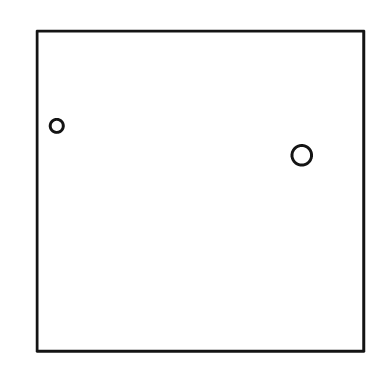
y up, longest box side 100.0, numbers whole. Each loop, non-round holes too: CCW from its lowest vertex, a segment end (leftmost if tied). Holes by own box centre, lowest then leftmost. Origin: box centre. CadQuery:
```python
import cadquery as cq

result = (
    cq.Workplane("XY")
    .moveTo(-50.0, -49.0)
    .lineTo(50.0, -49.0)
    .lineTo(50.0, 49.0)
    .lineTo(-50.0, 49.0)
    .close()
    .moveTo(31.0, 11.0)
    .circle(3.0)
    .moveTo(-44.0, 20.0)
    .circle(2.0)
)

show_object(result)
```